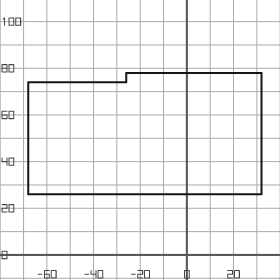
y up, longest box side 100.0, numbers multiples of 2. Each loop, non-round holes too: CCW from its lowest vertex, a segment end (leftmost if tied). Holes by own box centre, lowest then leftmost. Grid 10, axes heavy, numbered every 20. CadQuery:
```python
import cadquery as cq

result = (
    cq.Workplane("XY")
    .moveTo(-68.0, 26.0)
    .lineTo(32.0, 26.0)
    .lineTo(32.0, 78.0)
    .lineTo(-26.0, 78.0)
    .lineTo(-26.0, 74.0)
    .lineTo(-68.0, 74.0)
    .close()
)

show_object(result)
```